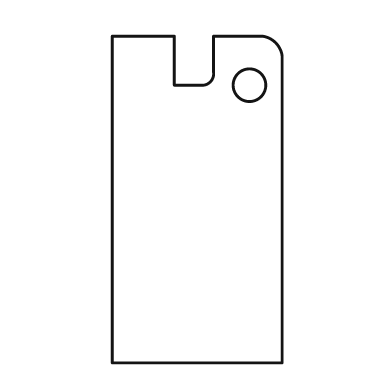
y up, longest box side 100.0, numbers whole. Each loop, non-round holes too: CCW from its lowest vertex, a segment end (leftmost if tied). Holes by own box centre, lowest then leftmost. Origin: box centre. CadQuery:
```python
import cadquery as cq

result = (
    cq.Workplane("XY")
    .moveTo(-26.0, -50.0)
    .lineTo(26.0, -50.0)
    .lineTo(26.0, 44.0)
    .threePointArc((24.0, 48.0), (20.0, 50.0))
    .lineTo(5.0, 50.0)
    .lineTo(5.0, 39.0)
    .threePointArc((4.0, 36.0), (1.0, 35.0))
    .lineTo(-7.0, 35.0)
    .lineTo(-7.0, 50.0)
    .lineTo(-26.0, 50.0)
    .close()
    .moveTo(16.0, 35.0)
    .circle(5.0)
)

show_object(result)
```